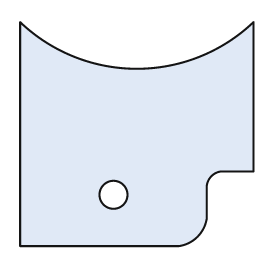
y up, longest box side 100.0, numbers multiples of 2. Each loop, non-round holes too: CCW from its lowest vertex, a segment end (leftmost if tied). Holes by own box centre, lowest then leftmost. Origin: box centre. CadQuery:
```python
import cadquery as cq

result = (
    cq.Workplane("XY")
    .moveTo(-50.0, -48.0)
    .lineTo(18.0, -48.0)
    .threePointArc((26.0, -44.0), (30.0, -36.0))
    .lineTo(30.0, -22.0)
    .threePointArc((32.0, -18.0), (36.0, -16.0))
    .lineTo(50.0, -16.0)
    .lineTo(50.0, 48.0)
    .threePointArc((0.0, 28.0), (-50.0, 48.0))
    .close()
    .moveTo(-10.0, -26.0)
    .circle(6.0)
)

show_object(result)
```